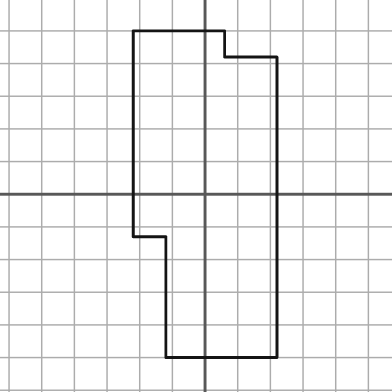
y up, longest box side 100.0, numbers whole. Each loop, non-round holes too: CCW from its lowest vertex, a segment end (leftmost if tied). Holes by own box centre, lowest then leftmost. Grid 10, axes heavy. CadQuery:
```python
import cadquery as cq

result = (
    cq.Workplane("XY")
    .moveTo(-12.0, -50.0)
    .lineTo(22.0, -50.0)
    .lineTo(22.0, 42.0)
    .lineTo(6.0, 42.0)
    .lineTo(6.0, 50.0)
    .lineTo(-22.0, 50.0)
    .lineTo(-22.0, -13.0)
    .lineTo(-12.0, -13.0)
    .close()
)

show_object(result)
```